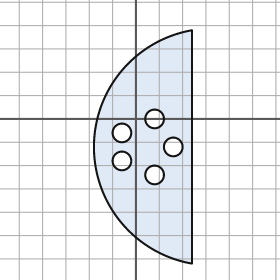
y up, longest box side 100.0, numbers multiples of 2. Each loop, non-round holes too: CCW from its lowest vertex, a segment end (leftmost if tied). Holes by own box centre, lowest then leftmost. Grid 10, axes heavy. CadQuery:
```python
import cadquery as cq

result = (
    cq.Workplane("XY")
    .moveTo(24.0, -62.0)
    .lineTo(24.0, 38.0)
    .threePointArc((-18.0, -12.0), (24.0, -62.0))
    .close()
    .moveTo(8.0, -24.0)
    .circle(4.0)
    .moveTo(-6.0, -18.0)
    .circle(4.0)
    .moveTo(16.0, -12.0)
    .circle(4.0)
    .moveTo(-6.0, -6.0)
    .circle(4.0)
    .moveTo(8.0, 0.0)
    .circle(4.0)
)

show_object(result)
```